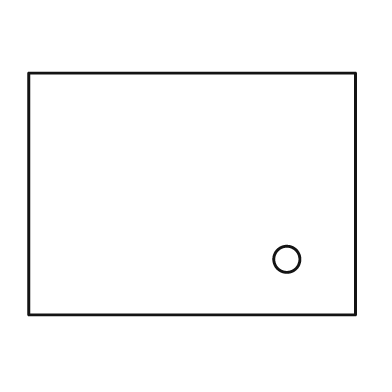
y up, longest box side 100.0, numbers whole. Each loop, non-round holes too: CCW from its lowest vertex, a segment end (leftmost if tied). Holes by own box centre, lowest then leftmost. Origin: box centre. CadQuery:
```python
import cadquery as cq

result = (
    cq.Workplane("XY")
    .moveTo(-50.0, -37.0)
    .lineTo(50.0, -37.0)
    .lineTo(50.0, 37.0)
    .lineTo(-50.0, 37.0)
    .close()
    .moveTo(29.0, -20.0)
    .circle(4.0)
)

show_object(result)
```